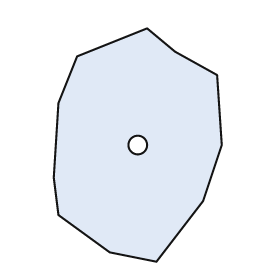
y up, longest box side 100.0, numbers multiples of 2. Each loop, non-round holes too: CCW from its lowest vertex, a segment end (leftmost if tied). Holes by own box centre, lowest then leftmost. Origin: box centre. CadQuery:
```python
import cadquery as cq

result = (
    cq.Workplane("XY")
    .moveTo(8.0, -50.0)
    .lineTo(28.0, -24.0)
    .lineTo(36.0, 0.0)
    .lineTo(34.0, 30.0)
    .lineTo(16.0, 40.0)
    .lineTo(4.0, 50.0)
    .lineTo(-26.0, 38.0)
    .lineTo(-34.0, 18.0)
    .lineTo(-36.0, -14.0)
    .lineTo(-34.0, -30.0)
    .lineTo(-12.0, -46.0)
    .close()
    .moveTo(0.0, 0.0)
    .circle(4.0)
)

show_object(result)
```